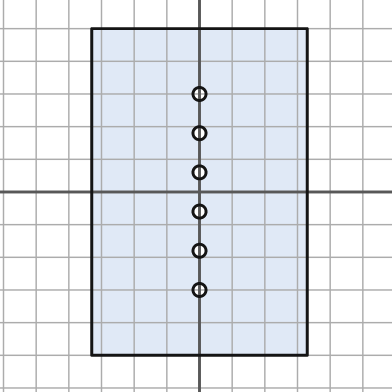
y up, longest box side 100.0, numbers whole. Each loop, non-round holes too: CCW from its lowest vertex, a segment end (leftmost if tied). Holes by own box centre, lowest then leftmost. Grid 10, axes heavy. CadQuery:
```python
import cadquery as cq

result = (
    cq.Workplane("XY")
    .moveTo(-33.0, -50.0)
    .lineTo(33.0, -50.0)
    .lineTo(33.0, 50.0)
    .lineTo(-33.0, 50.0)
    .close()
    .moveTo(0.0, -30.0)
    .circle(2.0)
    .moveTo(0.0, -18.0)
    .circle(2.0)
    .moveTo(0.0, -6.0)
    .circle(2.0)
    .moveTo(0.0, 6.0)
    .circle(2.0)
    .moveTo(0.0, 18.0)
    .circle(2.0)
    .moveTo(0.0, 30.0)
    .circle(2.0)
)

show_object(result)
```